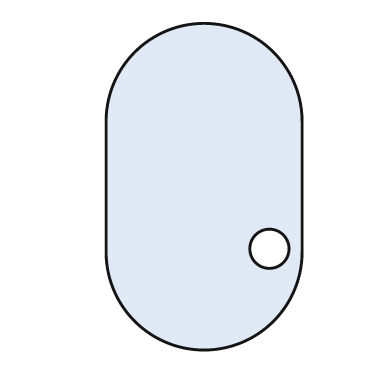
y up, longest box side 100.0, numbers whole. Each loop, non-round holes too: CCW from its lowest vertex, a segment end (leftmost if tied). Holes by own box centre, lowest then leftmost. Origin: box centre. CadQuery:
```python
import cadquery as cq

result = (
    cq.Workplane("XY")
    .moveTo(-30.0, -20.0)
    .threePointArc((0.0, -50.0), (30.0, -20.0))
    .lineTo(30.0, 20.0)
    .threePointArc((0.0, 50.0), (-30.0, 20.0))
    .close()
    .moveTo(20.0, -19.0)
    .circle(6.0)
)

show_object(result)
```